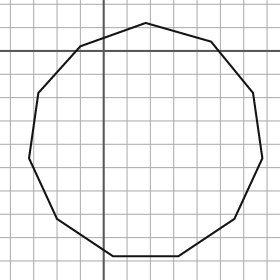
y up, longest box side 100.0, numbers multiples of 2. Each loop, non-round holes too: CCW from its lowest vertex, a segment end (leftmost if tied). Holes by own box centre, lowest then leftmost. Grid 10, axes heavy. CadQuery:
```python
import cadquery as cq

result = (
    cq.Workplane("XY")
    .moveTo(4.0, -88.0)
    .lineTo(32.0, -88.0)
    .lineTo(56.0, -72.0)
    .lineTo(68.0, -46.0)
    .lineTo(64.0, -18.0)
    .lineTo(46.0, 4.0)
    .lineTo(18.0, 12.0)
    .lineTo(-10.0, 2.0)
    .lineTo(-28.0, -18.0)
    .lineTo(-32.0, -46.0)
    .lineTo(-20.0, -72.0)
    .close()
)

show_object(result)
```